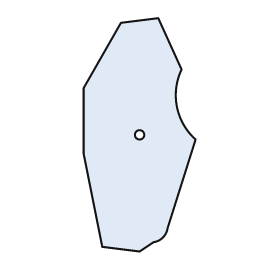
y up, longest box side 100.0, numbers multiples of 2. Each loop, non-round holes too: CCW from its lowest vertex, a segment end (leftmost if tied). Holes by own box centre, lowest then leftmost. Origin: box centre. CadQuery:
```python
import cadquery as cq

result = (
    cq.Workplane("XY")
    .moveTo(0.0, -50.0)
    .lineTo(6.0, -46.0)
    .threePointArc((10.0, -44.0), (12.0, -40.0))
    .lineTo(24.0, -2.0)
    .threePointArc((16.0, 12.0), (18.0, 28.0))
    .lineTo(8.0, 50.0)
    .lineTo(-8.0, 48.0)
    .lineTo(-24.0, 20.0)
    .lineTo(-24.0, -8.0)
    .lineTo(-16.0, -48.0)
    .close()
    .moveTo(0.0, 0.0)
    .circle(2.0)
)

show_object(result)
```